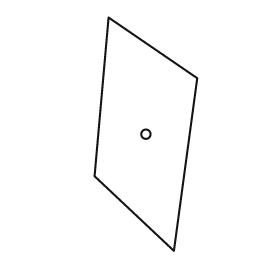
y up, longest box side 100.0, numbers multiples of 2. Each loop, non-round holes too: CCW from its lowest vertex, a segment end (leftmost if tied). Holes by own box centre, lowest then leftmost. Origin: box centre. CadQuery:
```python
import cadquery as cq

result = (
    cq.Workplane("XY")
    .moveTo(12.0, -50.0)
    .lineTo(22.0, 24.0)
    .lineTo(-16.0, 50.0)
    .lineTo(-22.0, -18.0)
    .close()
    .moveTo(0.0, 0.0)
    .circle(2.0)
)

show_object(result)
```